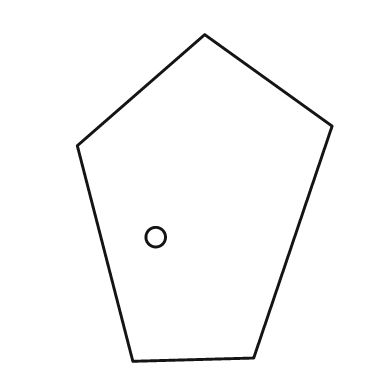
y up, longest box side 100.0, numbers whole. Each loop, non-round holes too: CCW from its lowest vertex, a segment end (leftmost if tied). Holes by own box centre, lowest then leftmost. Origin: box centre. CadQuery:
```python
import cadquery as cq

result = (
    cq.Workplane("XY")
    .moveTo(-22.0, -50.0)
    .lineTo(15.0, -49.0)
    .lineTo(39.0, 22.0)
    .lineTo(0.0, 50.0)
    .lineTo(-39.0, 16.0)
    .close()
    .moveTo(-15.0, -12.0)
    .circle(3.0)
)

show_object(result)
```